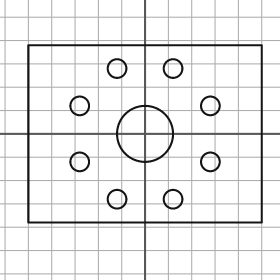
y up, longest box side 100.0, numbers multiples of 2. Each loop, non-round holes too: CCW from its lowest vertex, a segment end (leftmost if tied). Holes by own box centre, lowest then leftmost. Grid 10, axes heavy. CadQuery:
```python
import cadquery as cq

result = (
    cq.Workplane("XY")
    .moveTo(-50.0, -38.0)
    .lineTo(50.0, -38.0)
    .lineTo(50.0, 38.0)
    .lineTo(-50.0, 38.0)
    .close()
    .moveTo(-12.0, -28.0)
    .circle(4.0)
    .moveTo(12.0, -28.0)
    .circle(4.0)
    .moveTo(-28.0, -12.0)
    .circle(4.0)
    .moveTo(28.0, -12.0)
    .circle(4.0)
    .moveTo(0.0, 0.0)
    .circle(12.0)
    .moveTo(-28.0, 12.0)
    .circle(4.0)
    .moveTo(28.0, 12.0)
    .circle(4.0)
    .moveTo(-12.0, 28.0)
    .circle(4.0)
    .moveTo(12.0, 28.0)
    .circle(4.0)
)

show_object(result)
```